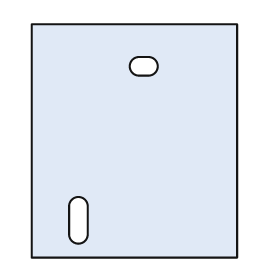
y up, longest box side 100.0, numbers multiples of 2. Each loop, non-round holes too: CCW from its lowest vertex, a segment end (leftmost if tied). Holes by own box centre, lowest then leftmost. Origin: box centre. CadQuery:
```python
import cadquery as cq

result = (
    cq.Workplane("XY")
    .moveTo(-44.0, -50.0)
    .lineTo(44.0, -50.0)
    .lineTo(44.0, 50.0)
    .lineTo(-44.0, 50.0)
    .close()
    .moveTo(-28.0, -40.0)
    .threePointArc((-24.0, -44.0), (-20.0, -40.0))
    .lineTo(-20.0, -28.0)
    .threePointArc((-24.0, -24.0), (-28.0, -28.0))
    .close()
    .moveTo(2.0, 28.0)
    .lineTo(6.0, 28.0)
    .threePointArc((10.0, 32.0), (6.0, 36.0))
    .lineTo(2.0, 36.0)
    .threePointArc((-2.0, 32.0), (2.0, 28.0))
    .close()
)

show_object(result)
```